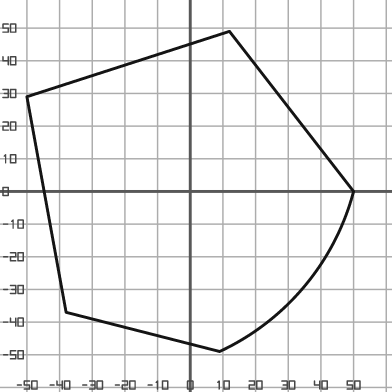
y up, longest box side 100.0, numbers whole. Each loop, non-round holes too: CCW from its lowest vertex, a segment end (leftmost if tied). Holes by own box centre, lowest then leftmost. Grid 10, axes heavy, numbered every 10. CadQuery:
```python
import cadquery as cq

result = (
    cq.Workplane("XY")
    .moveTo(9.0, -49.0)
    .threePointArc((35.0, -29.0), (50.0, 0.0))
    .lineTo(12.0, 49.0)
    .lineTo(-50.0, 29.0)
    .lineTo(-38.0, -37.0)
    .close()
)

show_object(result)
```